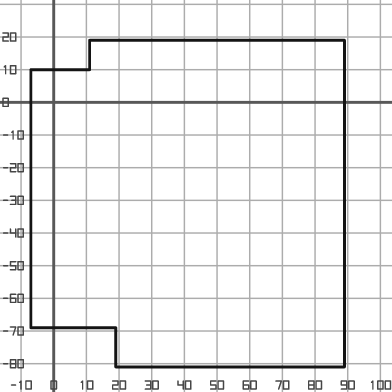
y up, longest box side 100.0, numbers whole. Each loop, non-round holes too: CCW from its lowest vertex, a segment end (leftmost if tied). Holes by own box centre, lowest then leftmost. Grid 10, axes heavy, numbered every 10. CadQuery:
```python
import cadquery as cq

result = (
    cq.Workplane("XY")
    .moveTo(19.0, -81.0)
    .lineTo(89.0, -81.0)
    .lineTo(89.0, 19.0)
    .lineTo(11.0, 19.0)
    .lineTo(11.0, 10.0)
    .lineTo(-7.0, 10.0)
    .lineTo(-7.0, -69.0)
    .lineTo(19.0, -69.0)
    .close()
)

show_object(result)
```